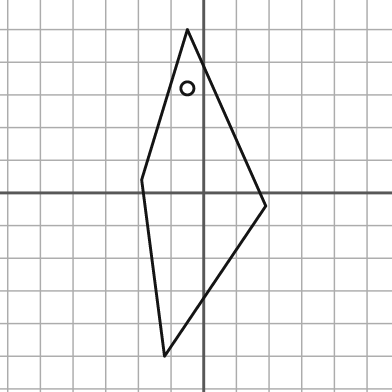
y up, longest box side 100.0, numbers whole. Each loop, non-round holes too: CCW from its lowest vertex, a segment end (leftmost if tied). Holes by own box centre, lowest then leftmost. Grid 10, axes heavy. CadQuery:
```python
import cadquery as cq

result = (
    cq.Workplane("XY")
    .moveTo(-12.0, -50.0)
    .lineTo(19.0, -4.0)
    .lineTo(-5.0, 50.0)
    .lineTo(-19.0, 4.0)
    .close()
    .moveTo(-5.0, 32.0)
    .circle(2.0)
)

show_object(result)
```